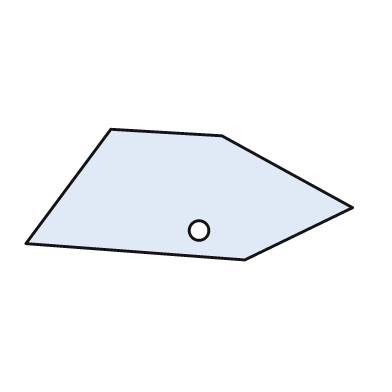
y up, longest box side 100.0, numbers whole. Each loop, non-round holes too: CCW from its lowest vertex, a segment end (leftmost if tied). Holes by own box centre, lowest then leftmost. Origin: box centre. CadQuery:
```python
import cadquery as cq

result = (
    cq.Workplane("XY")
    .moveTo(17.0, -20.0)
    .lineTo(50.0, -4.0)
    .lineTo(10.0, 18.0)
    .lineTo(-24.0, 20.0)
    .lineTo(-50.0, -15.0)
    .close()
    .moveTo(3.0, -11.0)
    .circle(3.0)
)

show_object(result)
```